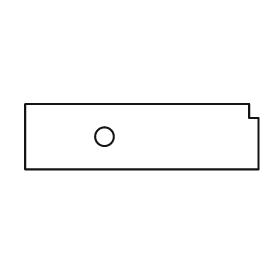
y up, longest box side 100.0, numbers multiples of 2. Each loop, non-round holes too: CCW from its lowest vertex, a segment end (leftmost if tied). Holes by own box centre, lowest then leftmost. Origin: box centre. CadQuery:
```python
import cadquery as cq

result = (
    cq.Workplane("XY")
    .moveTo(-50.0, -14.0)
    .lineTo(50.0, -14.0)
    .lineTo(50.0, 8.0)
    .lineTo(46.0, 8.0)
    .lineTo(46.0, 14.0)
    .lineTo(-50.0, 14.0)
    .close()
    .moveTo(-16.0, 0.0)
    .circle(4.0)
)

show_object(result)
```